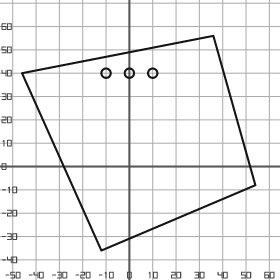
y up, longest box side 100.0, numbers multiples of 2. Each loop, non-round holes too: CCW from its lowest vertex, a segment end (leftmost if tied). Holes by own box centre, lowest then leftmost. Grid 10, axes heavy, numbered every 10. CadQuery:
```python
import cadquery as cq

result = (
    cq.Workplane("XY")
    .moveTo(-12.0, -36.0)
    .lineTo(54.0, -8.0)
    .lineTo(36.0, 56.0)
    .lineTo(-46.0, 40.0)
    .close()
    .moveTo(-10.0, 40.0)
    .circle(2.0)
    .moveTo(0.0, 40.0)
    .circle(2.0)
    .moveTo(10.0, 40.0)
    .circle(2.0)
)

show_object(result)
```